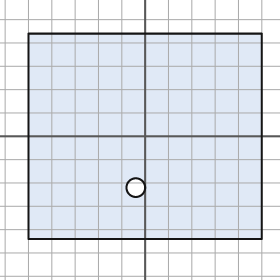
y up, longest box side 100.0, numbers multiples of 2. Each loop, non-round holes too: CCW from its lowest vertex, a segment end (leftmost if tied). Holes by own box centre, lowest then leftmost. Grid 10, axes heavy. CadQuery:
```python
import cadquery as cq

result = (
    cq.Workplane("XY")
    .moveTo(-50.0, -44.0)
    .lineTo(50.0, -44.0)
    .lineTo(50.0, 44.0)
    .lineTo(-50.0, 44.0)
    .close()
    .moveTo(-4.0, -22.0)
    .circle(4.0)
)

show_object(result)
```